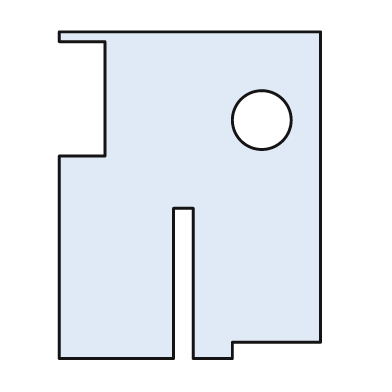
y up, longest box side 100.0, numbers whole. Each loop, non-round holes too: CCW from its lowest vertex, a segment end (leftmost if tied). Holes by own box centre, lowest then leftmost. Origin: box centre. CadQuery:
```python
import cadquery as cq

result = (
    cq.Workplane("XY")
    .moveTo(-40.0, -50.0)
    .lineTo(-5.0, -50.0)
    .lineTo(-5.0, -4.0)
    .lineTo(1.0, -4.0)
    .lineTo(1.0, -50.0)
    .lineTo(13.0, -50.0)
    .lineTo(13.0, -45.0)
    .lineTo(40.0, -45.0)
    .lineTo(40.0, 50.0)
    .lineTo(-40.0, 50.0)
    .lineTo(-40.0, 47.0)
    .lineTo(-26.0, 47.0)
    .lineTo(-26.0, 12.0)
    .lineTo(-40.0, 12.0)
    .close()
    .moveTo(22.0, 23.0)
    .circle(9.0)
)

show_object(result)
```